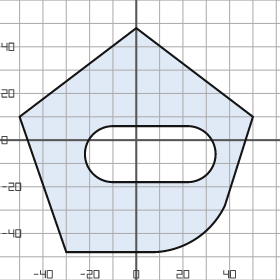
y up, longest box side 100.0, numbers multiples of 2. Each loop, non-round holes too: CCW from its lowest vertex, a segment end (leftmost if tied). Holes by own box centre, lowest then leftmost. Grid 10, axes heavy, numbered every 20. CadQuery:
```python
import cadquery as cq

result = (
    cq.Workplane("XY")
    .moveTo(-30.0, -48.0)
    .lineTo(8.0, -48.0)
    .threePointArc((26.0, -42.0), (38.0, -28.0))
    .lineTo(50.0, 10.0)
    .lineTo(0.0, 48.0)
    .lineTo(-50.0, 10.0)
    .close()
    .moveTo(-10.0, -18.0)
    .lineTo(22.0, -18.0)
    .threePointArc((34.0, -6.0), (22.0, 6.0))
    .lineTo(-10.0, 6.0)
    .threePointArc((-22.0, -6.0), (-10.0, -18.0))
    .close()
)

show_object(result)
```